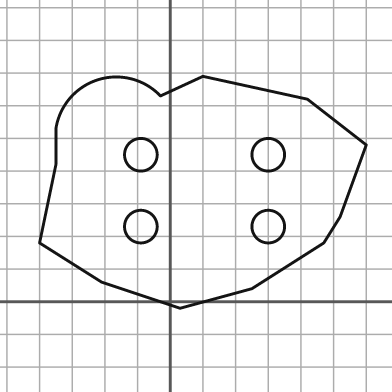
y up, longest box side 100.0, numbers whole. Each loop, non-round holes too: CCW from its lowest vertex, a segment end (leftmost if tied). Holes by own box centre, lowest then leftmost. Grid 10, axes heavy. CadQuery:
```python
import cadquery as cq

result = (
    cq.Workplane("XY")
    .moveTo(3.0, -2.0)
    .lineTo(25.0, 4.0)
    .lineTo(47.0, 18.0)
    .lineTo(52.0, 26.0)
    .lineTo(60.0, 48.0)
    .lineTo(42.0, 62.0)
    .lineTo(10.0, 69.0)
    .lineTo(-3.0, 63.0)
    .threePointArc((-22.0, 68.0), (-35.0, 53.0))
    .lineTo(-35.0, 42.0)
    .lineTo(-40.0, 18.0)
    .lineTo(-21.0, 6.0)
    .close()
    .moveTo(-9.0, 23.0)
    .circle(5.0)
    .moveTo(30.0, 23.0)
    .circle(5.0)
    .moveTo(-9.0, 45.0)
    .circle(5.0)
    .moveTo(30.0, 45.0)
    .circle(5.0)
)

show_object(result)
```